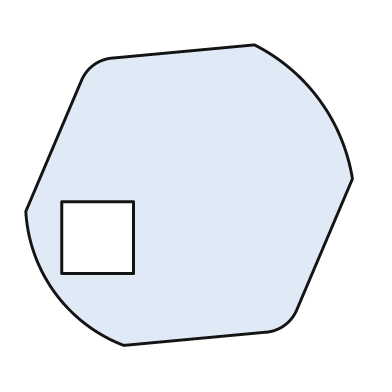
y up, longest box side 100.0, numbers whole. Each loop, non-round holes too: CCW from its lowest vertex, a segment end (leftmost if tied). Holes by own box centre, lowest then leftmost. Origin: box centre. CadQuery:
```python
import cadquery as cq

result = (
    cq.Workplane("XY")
    .moveTo(-20.0, -46.0)
    .lineTo(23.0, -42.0)
    .threePointArc((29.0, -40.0), (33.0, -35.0))
    .lineTo(50.0, 5.0)
    .threePointArc((40.0, 29.0), (20.0, 46.0))
    .lineTo(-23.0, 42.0)
    .threePointArc((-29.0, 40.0), (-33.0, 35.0))
    .lineTo(-50.0, -5.0)
    .threePointArc((-41.0, -30.0), (-20.0, -46.0))
    .close()
    .moveTo(-39.0, -24.0)
    .lineTo(-17.0, -24.0)
    .lineTo(-17.0, -2.0)
    .lineTo(-39.0, -2.0)
    .close()
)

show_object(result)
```